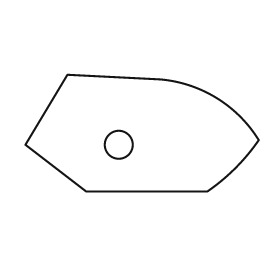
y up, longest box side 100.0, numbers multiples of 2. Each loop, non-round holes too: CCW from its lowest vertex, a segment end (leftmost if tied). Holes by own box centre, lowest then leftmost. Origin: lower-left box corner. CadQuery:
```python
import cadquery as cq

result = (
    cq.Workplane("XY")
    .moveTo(26.0, 0.0)
    .lineTo(78.0, 0.0)
    .threePointArc((90.0, 10.0), (100.0, 22.0))
    .threePointArc((82.0, 40.0), (58.0, 48.0))
    .lineTo(18.0, 50.0)
    .lineTo(0.0, 20.0)
    .close()
    .moveTo(40.0, 20.0)
    .circle(6.0)
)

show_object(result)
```